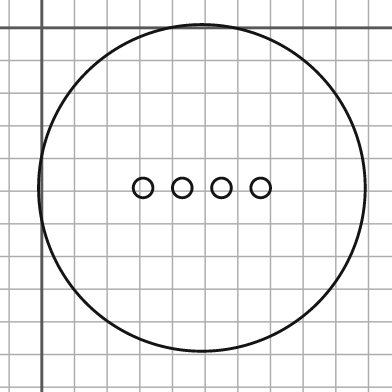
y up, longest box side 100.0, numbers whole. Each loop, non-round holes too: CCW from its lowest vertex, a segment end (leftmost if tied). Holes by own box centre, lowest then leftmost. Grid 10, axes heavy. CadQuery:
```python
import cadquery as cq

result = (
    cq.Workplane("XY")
    .moveTo(49.0, -49.0)
    .circle(50.0)
    .moveTo(31.0, -49.0)
    .circle(3.0)
    .moveTo(43.0, -49.0)
    .circle(3.0)
    .moveTo(55.0, -49.0)
    .circle(3.0)
    .moveTo(67.0, -49.0)
    .circle(3.0)
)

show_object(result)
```